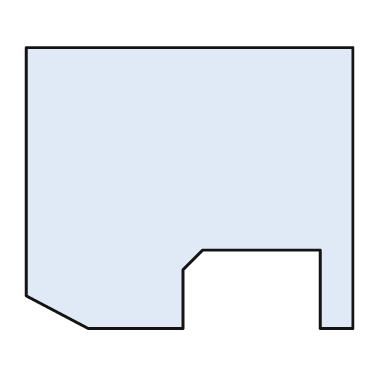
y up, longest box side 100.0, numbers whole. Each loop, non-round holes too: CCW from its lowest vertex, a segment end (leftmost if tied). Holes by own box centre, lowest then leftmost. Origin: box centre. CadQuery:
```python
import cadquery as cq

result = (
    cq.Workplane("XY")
    .moveTo(-31.0, -43.0)
    .lineTo(-2.0, -43.0)
    .lineTo(-2.0, -25.0)
    .lineTo(4.0, -19.0)
    .lineTo(40.0, -19.0)
    .lineTo(40.0, -43.0)
    .lineTo(50.0, -43.0)
    .lineTo(50.0, 43.0)
    .lineTo(-50.0, 43.0)
    .lineTo(-50.0, -33.0)
    .close()
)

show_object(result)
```